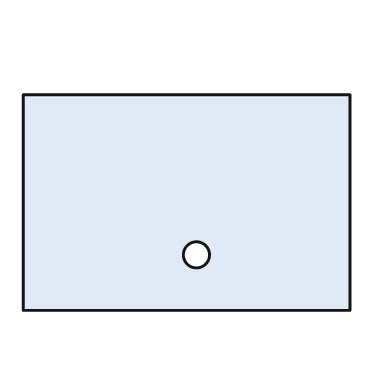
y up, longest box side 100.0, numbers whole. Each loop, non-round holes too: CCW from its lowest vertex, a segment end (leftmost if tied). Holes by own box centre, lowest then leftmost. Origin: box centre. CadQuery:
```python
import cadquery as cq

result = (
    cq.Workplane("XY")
    .moveTo(-50.0, -33.0)
    .lineTo(50.0, -33.0)
    .lineTo(50.0, 33.0)
    .lineTo(-50.0, 33.0)
    .close()
    .moveTo(3.0, -16.0)
    .circle(4.0)
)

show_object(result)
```